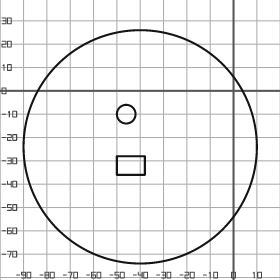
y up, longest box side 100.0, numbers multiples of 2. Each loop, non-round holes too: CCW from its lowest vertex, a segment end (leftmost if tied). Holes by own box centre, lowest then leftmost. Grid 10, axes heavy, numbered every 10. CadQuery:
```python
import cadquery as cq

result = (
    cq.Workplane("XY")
    .moveTo(-40.0, -24.0)
    .circle(50.0)
    .moveTo(-50.0, -36.0)
    .lineTo(-38.0, -36.0)
    .lineTo(-38.0, -28.0)
    .lineTo(-50.0, -28.0)
    .close()
    .moveTo(-46.0, -10.0)
    .circle(4.0)
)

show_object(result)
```